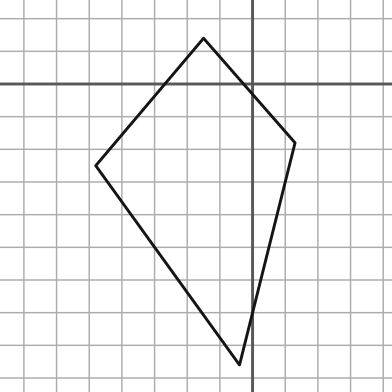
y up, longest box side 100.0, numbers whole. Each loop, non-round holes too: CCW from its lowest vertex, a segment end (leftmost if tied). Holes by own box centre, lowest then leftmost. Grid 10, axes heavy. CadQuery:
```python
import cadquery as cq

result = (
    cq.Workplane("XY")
    .moveTo(-4.0, -86.0)
    .lineTo(13.0, -18.0)
    .lineTo(-15.0, 14.0)
    .lineTo(-48.0, -25.0)
    .close()
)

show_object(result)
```